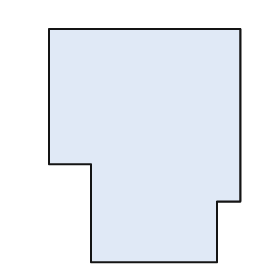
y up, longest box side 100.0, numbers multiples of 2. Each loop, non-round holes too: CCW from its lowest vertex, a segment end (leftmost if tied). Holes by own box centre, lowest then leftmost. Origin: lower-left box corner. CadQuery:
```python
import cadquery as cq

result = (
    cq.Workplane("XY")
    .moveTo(18.0, 0.0)
    .lineTo(72.0, 0.0)
    .lineTo(72.0, 26.0)
    .lineTo(82.0, 26.0)
    .lineTo(82.0, 100.0)
    .lineTo(0.0, 100.0)
    .lineTo(0.0, 42.0)
    .lineTo(18.0, 42.0)
    .close()
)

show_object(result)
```